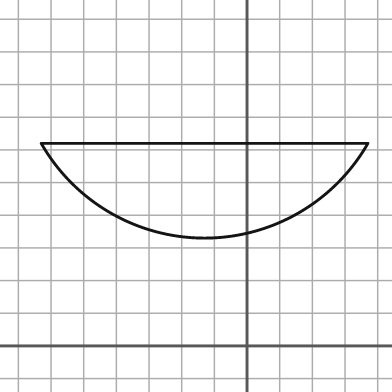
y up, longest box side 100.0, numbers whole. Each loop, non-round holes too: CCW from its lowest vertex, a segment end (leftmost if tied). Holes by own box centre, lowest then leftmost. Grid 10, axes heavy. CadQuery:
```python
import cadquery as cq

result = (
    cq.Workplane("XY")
    .moveTo(-63.0, 62.0)
    .threePointArc((-13.0, 33.0), (37.0, 62.0))
    .close()
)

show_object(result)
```